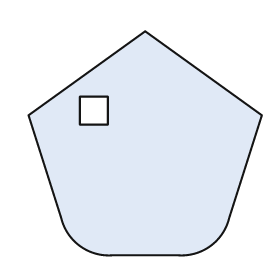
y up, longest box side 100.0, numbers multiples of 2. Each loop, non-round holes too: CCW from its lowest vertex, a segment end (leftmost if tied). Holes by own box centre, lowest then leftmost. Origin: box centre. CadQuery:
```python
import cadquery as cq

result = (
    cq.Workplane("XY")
    .moveTo(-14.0, -48.0)
    .lineTo(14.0, -48.0)
    .threePointArc((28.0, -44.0), (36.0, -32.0))
    .lineTo(50.0, 12.0)
    .lineTo(0.0, 48.0)
    .lineTo(-50.0, 12.0)
    .lineTo(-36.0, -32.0)
    .threePointArc((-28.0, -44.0), (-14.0, -48.0))
    .close()
    .moveTo(-28.0, 8.0)
    .lineTo(-16.0, 8.0)
    .lineTo(-16.0, 20.0)
    .lineTo(-28.0, 20.0)
    .close()
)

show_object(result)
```